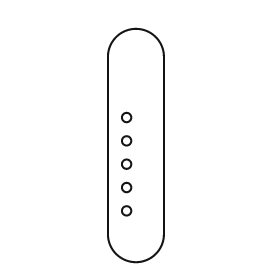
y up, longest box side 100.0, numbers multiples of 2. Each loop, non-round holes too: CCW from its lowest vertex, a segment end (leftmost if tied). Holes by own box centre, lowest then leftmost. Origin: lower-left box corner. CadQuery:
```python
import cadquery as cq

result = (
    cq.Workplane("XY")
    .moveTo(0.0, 12.0)
    .threePointArc((12.0, 0.0), (24.0, 12.0))
    .lineTo(24.0, 88.0)
    .threePointArc((12.0, 100.0), (0.0, 88.0))
    .close()
    .moveTo(8.0, 22.0)
    .circle(2.0)
    .moveTo(8.0, 32.0)
    .circle(2.0)
    .moveTo(8.0, 42.0)
    .circle(2.0)
    .moveTo(8.0, 52.0)
    .circle(2.0)
    .moveTo(8.0, 62.0)
    .circle(2.0)
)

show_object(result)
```